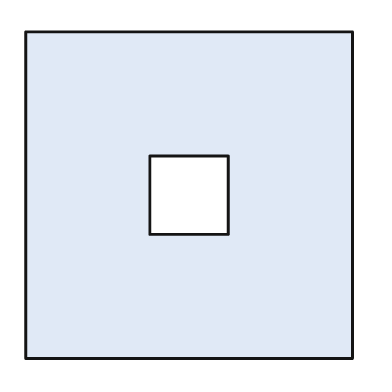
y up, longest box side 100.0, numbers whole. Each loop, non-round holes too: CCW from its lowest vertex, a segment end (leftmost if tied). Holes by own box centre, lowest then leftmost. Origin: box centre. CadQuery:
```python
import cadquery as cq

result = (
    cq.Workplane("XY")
    .moveTo(-50.0, -50.0)
    .lineTo(50.0, -50.0)
    .lineTo(50.0, 50.0)
    .lineTo(-50.0, 50.0)
    .close()
    .moveTo(-12.0, -12.0)
    .lineTo(12.0, -12.0)
    .lineTo(12.0, 12.0)
    .lineTo(-12.0, 12.0)
    .close()
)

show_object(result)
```